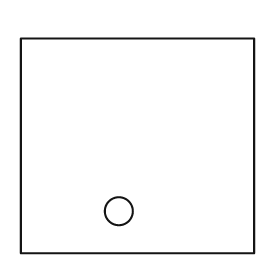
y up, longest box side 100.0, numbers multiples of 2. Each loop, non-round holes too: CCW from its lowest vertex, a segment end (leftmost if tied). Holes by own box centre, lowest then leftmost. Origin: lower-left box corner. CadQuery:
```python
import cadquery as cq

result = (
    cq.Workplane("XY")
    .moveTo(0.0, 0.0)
    .lineTo(100.0, 0.0)
    .lineTo(100.0, 92.0)
    .lineTo(0.0, 92.0)
    .close()
    .moveTo(42.0, 18.0)
    .circle(6.0)
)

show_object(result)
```